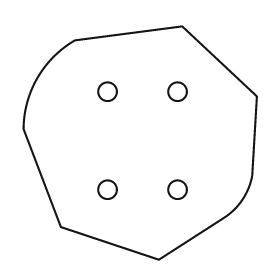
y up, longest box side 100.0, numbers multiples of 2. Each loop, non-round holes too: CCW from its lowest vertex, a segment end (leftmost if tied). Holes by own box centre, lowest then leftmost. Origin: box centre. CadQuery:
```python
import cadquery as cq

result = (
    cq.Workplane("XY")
    .moveTo(8.0, -50.0)
    .lineTo(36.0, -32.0)
    .threePointArc((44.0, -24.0), (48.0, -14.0))
    .lineTo(50.0, 20.0)
    .lineTo(18.0, 50.0)
    .lineTo(-28.0, 44.0)
    .threePointArc((-44.0, 28.0), (-50.0, 6.0))
    .lineTo(-34.0, -36.0)
    .close()
    .moveTo(-14.0, -20.0)
    .circle(4.0)
    .moveTo(16.0, -20.0)
    .circle(4.0)
    .moveTo(-14.0, 22.0)
    .circle(4.0)
    .moveTo(16.0, 22.0)
    .circle(4.0)
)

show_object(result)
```